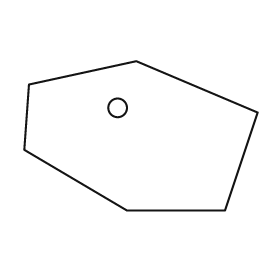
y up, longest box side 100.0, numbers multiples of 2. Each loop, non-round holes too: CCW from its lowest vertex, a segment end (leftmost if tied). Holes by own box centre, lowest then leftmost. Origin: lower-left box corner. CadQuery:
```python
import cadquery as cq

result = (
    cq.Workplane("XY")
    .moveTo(44.0, 0.0)
    .lineTo(86.0, 0.0)
    .lineTo(100.0, 42.0)
    .lineTo(48.0, 64.0)
    .lineTo(2.0, 54.0)
    .lineTo(0.0, 26.0)
    .close()
    .moveTo(40.0, 44.0)
    .circle(4.0)
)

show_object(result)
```